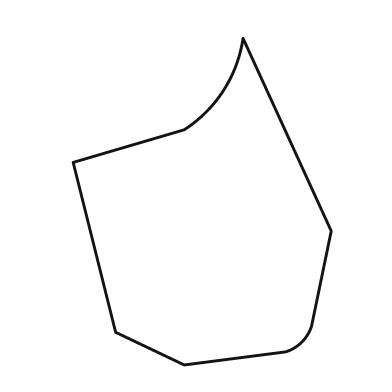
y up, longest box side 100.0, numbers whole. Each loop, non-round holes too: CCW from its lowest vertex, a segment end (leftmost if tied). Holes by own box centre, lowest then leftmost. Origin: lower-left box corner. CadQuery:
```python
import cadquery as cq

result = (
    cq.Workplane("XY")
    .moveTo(34.0, 0.0)
    .lineTo(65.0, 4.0)
    .threePointArc((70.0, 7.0), (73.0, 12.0))
    .lineTo(79.0, 41.0)
    .lineTo(52.0, 100.0)
    .threePointArc((46.0, 84.0), (34.0, 72.0))
    .lineTo(0.0, 62.0)
    .lineTo(13.0, 10.0)
    .close()
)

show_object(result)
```